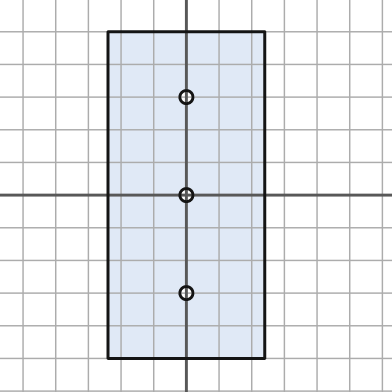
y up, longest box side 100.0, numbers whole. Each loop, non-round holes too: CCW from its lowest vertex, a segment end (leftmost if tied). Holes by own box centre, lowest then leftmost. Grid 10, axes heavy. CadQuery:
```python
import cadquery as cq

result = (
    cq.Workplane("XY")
    .moveTo(-24.0, -50.0)
    .lineTo(24.0, -50.0)
    .lineTo(24.0, 50.0)
    .lineTo(-24.0, 50.0)
    .close()
    .moveTo(0.0, -30.0)
    .circle(2.0)
    .moveTo(0.0, 0.0)
    .circle(2.0)
    .moveTo(0.0, 30.0)
    .circle(2.0)
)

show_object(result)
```